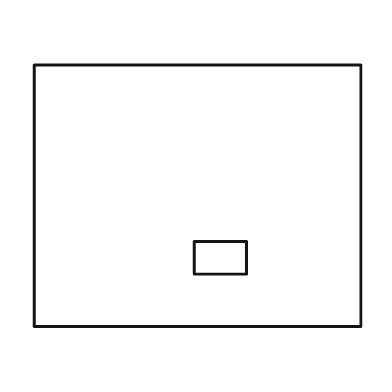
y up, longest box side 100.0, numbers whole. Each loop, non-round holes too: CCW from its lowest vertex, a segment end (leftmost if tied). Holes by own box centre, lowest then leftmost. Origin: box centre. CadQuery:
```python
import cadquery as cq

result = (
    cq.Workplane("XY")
    .moveTo(-50.0, -40.0)
    .lineTo(50.0, -40.0)
    .lineTo(50.0, 40.0)
    .lineTo(-50.0, 40.0)
    .close()
    .moveTo(-1.0, -24.0)
    .lineTo(15.0, -24.0)
    .lineTo(15.0, -14.0)
    .lineTo(-1.0, -14.0)
    .close()
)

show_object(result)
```